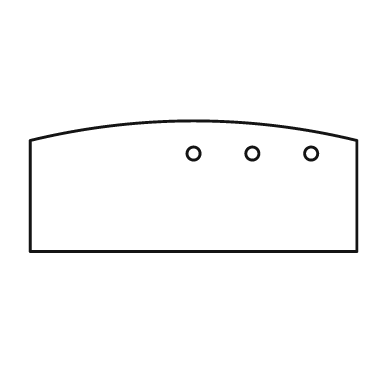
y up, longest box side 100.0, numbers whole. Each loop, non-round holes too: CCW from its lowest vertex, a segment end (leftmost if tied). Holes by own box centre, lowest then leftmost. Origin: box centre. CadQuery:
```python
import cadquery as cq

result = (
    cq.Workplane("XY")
    .moveTo(-50.0, -20.0)
    .lineTo(50.0, -20.0)
    .lineTo(50.0, 14.0)
    .threePointArc((0.0, 20.0), (-50.0, 14.0))
    .close()
    .moveTo(0.0, 10.0)
    .circle(2.0)
    .moveTo(18.0, 10.0)
    .circle(2.0)
    .moveTo(36.0, 10.0)
    .circle(2.0)
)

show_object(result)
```